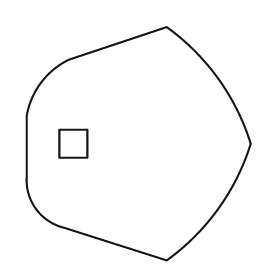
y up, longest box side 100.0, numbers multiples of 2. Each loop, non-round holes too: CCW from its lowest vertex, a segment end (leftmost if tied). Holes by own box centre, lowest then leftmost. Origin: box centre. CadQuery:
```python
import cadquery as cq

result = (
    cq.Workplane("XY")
    .moveTo(12.0, -50.0)
    .threePointArc((34.0, -28.0), (48.0, 0.0))
    .threePointArc((34.0, 28.0), (12.0, 50.0))
    .lineTo(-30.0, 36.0)
    .threePointArc((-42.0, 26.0), (-48.0, 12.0))
    .lineTo(-48.0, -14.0)
    .threePointArc((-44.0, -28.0), (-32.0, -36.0))
    .close()
    .moveTo(-34.0, -6.0)
    .lineTo(-22.0, -6.0)
    .lineTo(-22.0, 6.0)
    .lineTo(-34.0, 6.0)
    .close()
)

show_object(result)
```